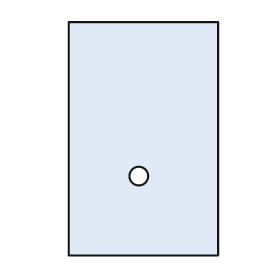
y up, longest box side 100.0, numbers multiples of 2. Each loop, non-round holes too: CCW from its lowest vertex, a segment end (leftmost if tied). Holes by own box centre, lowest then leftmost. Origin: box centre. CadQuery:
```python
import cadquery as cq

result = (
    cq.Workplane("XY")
    .moveTo(-32.0, -50.0)
    .lineTo(32.0, -50.0)
    .lineTo(32.0, 50.0)
    .lineTo(-32.0, 50.0)
    .close()
    .moveTo(-2.0, -16.0)
    .circle(4.0)
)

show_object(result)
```